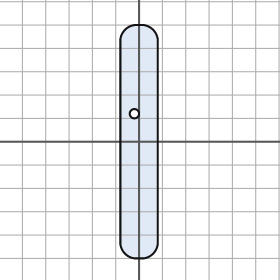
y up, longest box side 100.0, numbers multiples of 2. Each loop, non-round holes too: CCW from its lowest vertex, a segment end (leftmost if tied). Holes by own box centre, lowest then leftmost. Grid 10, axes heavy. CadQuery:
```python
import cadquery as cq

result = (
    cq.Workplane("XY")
    .moveTo(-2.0, -50.0)
    .lineTo(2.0, -50.0)
    .threePointArc((6.0, -48.0), (8.0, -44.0))
    .lineTo(8.0, 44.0)
    .threePointArc((6.0, 48.0), (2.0, 50.0))
    .lineTo(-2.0, 50.0)
    .threePointArc((-6.0, 48.0), (-8.0, 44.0))
    .lineTo(-8.0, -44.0)
    .threePointArc((-6.0, -48.0), (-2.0, -50.0))
    .close()
    .moveTo(-2.0, 12.0)
    .circle(2.0)
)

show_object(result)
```